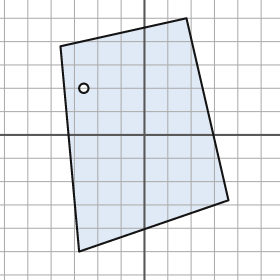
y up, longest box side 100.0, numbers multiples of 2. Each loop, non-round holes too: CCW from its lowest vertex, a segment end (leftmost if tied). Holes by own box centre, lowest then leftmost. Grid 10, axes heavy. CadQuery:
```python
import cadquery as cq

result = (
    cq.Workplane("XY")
    .moveTo(-28.0, -50.0)
    .lineTo(36.0, -28.0)
    .lineTo(18.0, 50.0)
    .lineTo(-36.0, 38.0)
    .close()
    .moveTo(-26.0, 20.0)
    .circle(2.0)
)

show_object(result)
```